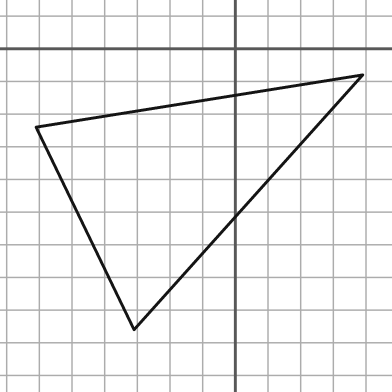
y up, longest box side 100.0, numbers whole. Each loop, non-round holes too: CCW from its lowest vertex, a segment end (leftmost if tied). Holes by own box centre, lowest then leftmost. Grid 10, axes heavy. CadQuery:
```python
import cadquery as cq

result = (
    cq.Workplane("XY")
    .moveTo(-31.0, -86.0)
    .lineTo(39.0, -8.0)
    .lineTo(-61.0, -24.0)
    .close()
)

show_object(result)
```